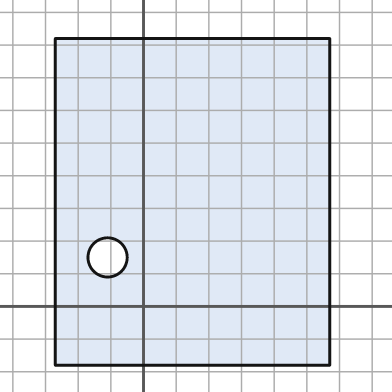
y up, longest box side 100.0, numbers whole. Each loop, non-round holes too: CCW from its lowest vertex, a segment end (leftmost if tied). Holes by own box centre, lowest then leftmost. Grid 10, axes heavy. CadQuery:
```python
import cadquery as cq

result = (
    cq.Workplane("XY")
    .moveTo(-27.0, -18.0)
    .lineTo(57.0, -18.0)
    .lineTo(57.0, 82.0)
    .lineTo(-27.0, 82.0)
    .close()
    .moveTo(-11.0, 15.0)
    .circle(6.0)
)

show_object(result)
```